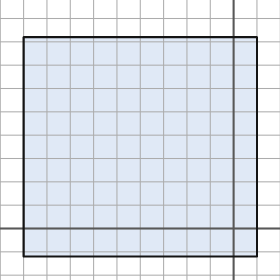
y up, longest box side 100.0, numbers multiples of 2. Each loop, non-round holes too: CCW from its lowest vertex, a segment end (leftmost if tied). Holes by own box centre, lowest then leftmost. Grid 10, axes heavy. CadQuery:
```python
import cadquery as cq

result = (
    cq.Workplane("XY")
    .moveTo(-90.0, -12.0)
    .lineTo(10.0, -12.0)
    .lineTo(10.0, 82.0)
    .lineTo(-90.0, 82.0)
    .close()
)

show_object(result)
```